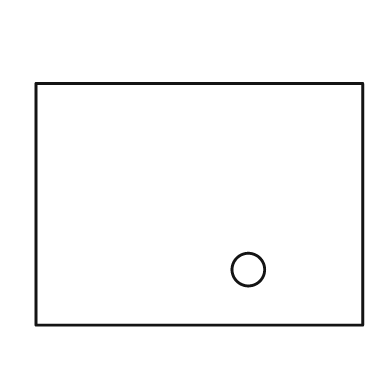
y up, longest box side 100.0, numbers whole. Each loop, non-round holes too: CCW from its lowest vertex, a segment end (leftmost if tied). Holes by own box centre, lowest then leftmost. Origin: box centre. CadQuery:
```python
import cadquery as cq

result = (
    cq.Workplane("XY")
    .moveTo(-50.0, -37.0)
    .lineTo(50.0, -37.0)
    .lineTo(50.0, 37.0)
    .lineTo(-50.0, 37.0)
    .close()
    .moveTo(15.0, -20.0)
    .circle(5.0)
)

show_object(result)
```